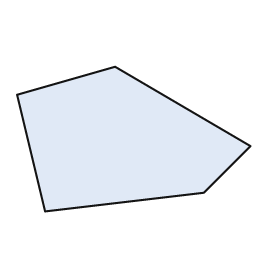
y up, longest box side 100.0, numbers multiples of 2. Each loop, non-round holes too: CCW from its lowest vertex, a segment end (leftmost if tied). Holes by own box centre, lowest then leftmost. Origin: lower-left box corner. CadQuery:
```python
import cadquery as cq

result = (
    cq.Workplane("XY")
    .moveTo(12.0, 0.0)
    .lineTo(80.0, 8.0)
    .lineTo(100.0, 28.0)
    .lineTo(42.0, 62.0)
    .lineTo(0.0, 50.0)
    .close()
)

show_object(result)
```